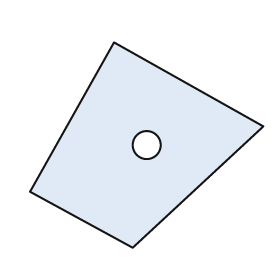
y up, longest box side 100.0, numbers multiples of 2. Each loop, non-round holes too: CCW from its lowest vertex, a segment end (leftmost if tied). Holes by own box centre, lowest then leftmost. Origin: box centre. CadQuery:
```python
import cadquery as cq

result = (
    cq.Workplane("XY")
    .moveTo(-6.0, -44.0)
    .lineTo(50.0, 8.0)
    .lineTo(-14.0, 44.0)
    .lineTo(-50.0, -20.0)
    .close()
    .moveTo(0.0, 0.0)
    .circle(6.0)
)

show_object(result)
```